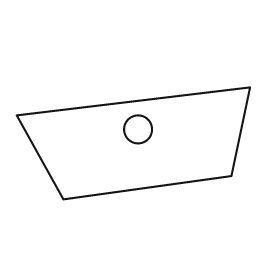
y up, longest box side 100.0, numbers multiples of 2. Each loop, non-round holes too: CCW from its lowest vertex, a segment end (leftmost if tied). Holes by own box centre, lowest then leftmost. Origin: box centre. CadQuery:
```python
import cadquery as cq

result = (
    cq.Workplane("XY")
    .moveTo(-30.0, -24.0)
    .lineTo(42.0, -14.0)
    .lineTo(50.0, 24.0)
    .lineTo(-50.0, 12.0)
    .close()
    .moveTo(2.0, 6.0)
    .circle(6.0)
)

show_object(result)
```